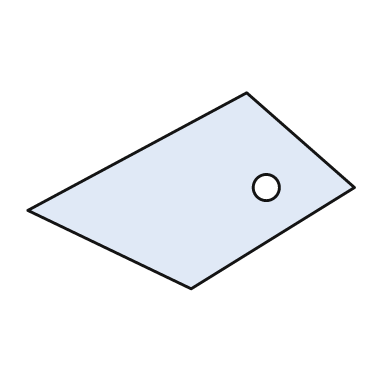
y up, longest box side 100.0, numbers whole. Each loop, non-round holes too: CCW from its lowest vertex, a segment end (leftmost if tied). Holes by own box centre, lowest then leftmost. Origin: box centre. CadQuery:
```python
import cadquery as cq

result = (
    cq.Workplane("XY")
    .moveTo(0.0, -30.0)
    .lineTo(50.0, 1.0)
    .lineTo(17.0, 30.0)
    .lineTo(-50.0, -6.0)
    .close()
    .moveTo(23.0, 1.0)
    .circle(4.0)
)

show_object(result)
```